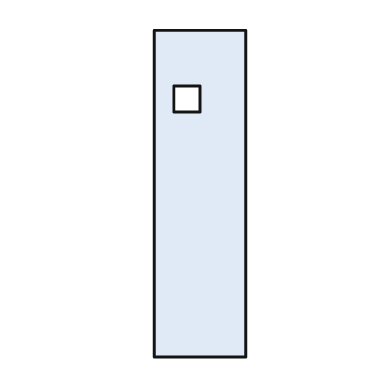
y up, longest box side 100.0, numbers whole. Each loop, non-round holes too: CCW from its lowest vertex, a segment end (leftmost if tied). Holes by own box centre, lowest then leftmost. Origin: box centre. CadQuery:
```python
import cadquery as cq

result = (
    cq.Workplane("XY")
    .moveTo(-14.0, -50.0)
    .lineTo(14.0, -50.0)
    .lineTo(14.0, 50.0)
    .lineTo(-14.0, 50.0)
    .close()
    .moveTo(-8.0, 25.0)
    .lineTo(0.0, 25.0)
    .lineTo(0.0, 33.0)
    .lineTo(-8.0, 33.0)
    .close()
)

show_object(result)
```